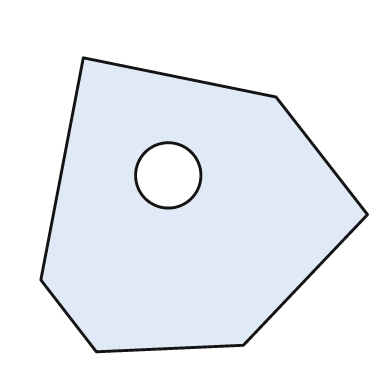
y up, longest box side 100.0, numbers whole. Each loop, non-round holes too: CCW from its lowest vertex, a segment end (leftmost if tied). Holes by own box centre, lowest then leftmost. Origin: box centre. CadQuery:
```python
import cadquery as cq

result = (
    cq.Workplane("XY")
    .moveTo(-33.0, -45.0)
    .lineTo(12.0, -43.0)
    .lineTo(50.0, -3.0)
    .lineTo(22.0, 33.0)
    .lineTo(-37.0, 45.0)
    .lineTo(-50.0, -23.0)
    .close()
    .moveTo(-11.0, 9.0)
    .circle(10.0)
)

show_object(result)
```